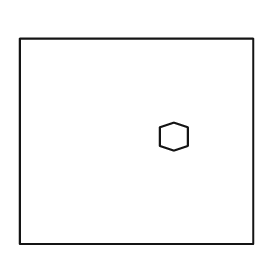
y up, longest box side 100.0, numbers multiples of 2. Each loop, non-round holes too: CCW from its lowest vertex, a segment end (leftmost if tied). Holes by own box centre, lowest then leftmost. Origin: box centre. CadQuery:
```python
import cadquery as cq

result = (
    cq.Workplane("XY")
    .moveTo(-50.0, -44.0)
    .lineTo(50.0, -44.0)
    .lineTo(50.0, 44.0)
    .lineTo(-50.0, 44.0)
    .close()
    .moveTo(16.0, -4.0)
    .lineTo(22.0, -2.0)
    .lineTo(22.0, 6.0)
    .lineTo(16.0, 8.0)
    .lineTo(10.0, 6.0)
    .lineTo(10.0, -2.0)
    .close()
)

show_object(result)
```